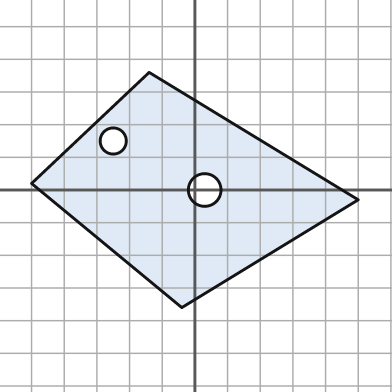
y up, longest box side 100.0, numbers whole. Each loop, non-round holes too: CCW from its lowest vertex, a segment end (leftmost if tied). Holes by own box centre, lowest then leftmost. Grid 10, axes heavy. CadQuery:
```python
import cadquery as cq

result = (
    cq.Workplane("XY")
    .moveTo(-4.0, -36.0)
    .lineTo(50.0, -3.0)
    .lineTo(-14.0, 36.0)
    .lineTo(-50.0, 2.0)
    .close()
    .moveTo(3.0, 0.0)
    .circle(5.0)
    .moveTo(-25.0, 15.0)
    .circle(4.0)
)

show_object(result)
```